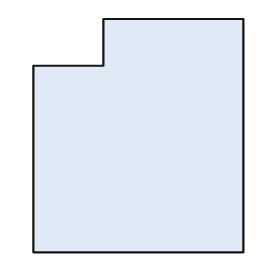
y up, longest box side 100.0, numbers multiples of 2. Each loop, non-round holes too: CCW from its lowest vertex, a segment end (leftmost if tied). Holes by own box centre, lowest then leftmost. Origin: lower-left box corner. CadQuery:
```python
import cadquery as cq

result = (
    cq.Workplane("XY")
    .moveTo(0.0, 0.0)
    .lineTo(90.0, 0.0)
    .lineTo(90.0, 100.0)
    .lineTo(30.0, 100.0)
    .lineTo(30.0, 80.0)
    .lineTo(0.0, 80.0)
    .close()
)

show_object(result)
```